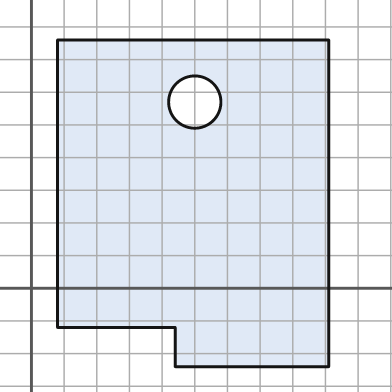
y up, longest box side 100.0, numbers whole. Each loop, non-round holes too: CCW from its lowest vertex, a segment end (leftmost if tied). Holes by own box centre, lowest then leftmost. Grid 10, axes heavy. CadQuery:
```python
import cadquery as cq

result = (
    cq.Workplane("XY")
    .moveTo(44.0, -24.0)
    .lineTo(91.0, -24.0)
    .lineTo(91.0, 76.0)
    .lineTo(8.0, 76.0)
    .lineTo(8.0, -12.0)
    .lineTo(44.0, -12.0)
    .close()
    .moveTo(50.0, 57.0)
    .circle(8.0)
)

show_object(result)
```